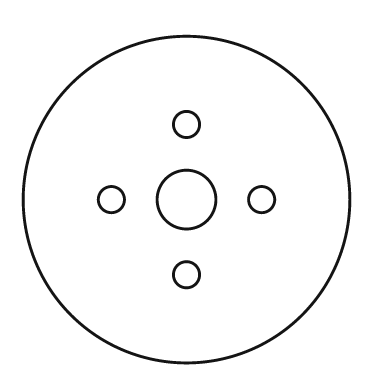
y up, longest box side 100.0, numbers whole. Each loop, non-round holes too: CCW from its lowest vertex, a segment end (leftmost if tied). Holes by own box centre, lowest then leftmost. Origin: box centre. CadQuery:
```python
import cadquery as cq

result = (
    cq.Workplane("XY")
    .moveTo(0.0, 0.0)
    .circle(50.0)
    .moveTo(0.0, -23.0)
    .circle(4.0)
    .moveTo(-23.0, 0.0)
    .circle(4.0)
    .moveTo(0.0, 0.0)
    .circle(9.0)
    .moveTo(23.0, 0.0)
    .circle(4.0)
    .moveTo(0.0, 23.0)
    .circle(4.0)
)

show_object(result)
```